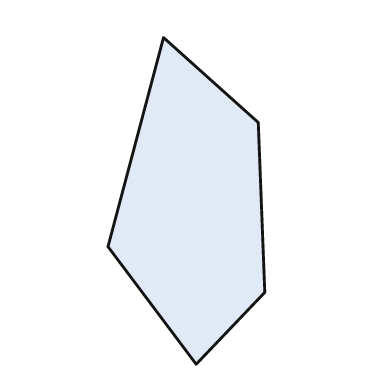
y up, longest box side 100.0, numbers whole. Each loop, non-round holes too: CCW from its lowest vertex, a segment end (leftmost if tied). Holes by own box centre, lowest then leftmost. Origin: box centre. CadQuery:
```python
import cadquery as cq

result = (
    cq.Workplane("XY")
    .moveTo(3.0, -50.0)
    .lineTo(24.0, -28.0)
    .lineTo(22.0, 24.0)
    .lineTo(-7.0, 50.0)
    .lineTo(-24.0, -14.0)
    .close()
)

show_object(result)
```